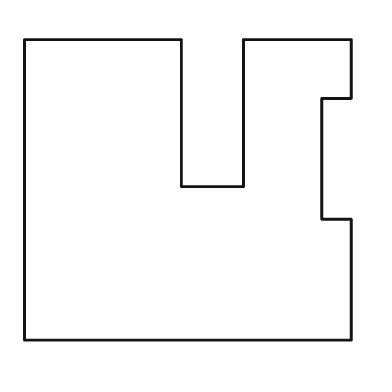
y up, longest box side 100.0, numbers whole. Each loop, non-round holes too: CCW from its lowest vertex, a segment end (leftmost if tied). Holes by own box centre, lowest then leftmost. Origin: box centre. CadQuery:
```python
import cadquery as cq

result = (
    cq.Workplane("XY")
    .moveTo(-50.0, -46.0)
    .lineTo(50.0, -46.0)
    .lineTo(50.0, -9.0)
    .lineTo(41.0, -9.0)
    .lineTo(41.0, 28.0)
    .lineTo(50.0, 28.0)
    .lineTo(50.0, 46.0)
    .lineTo(17.0, 46.0)
    .lineTo(17.0, 1.0)
    .lineTo(-2.0, 1.0)
    .lineTo(-2.0, 46.0)
    .lineTo(-50.0, 46.0)
    .close()
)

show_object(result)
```